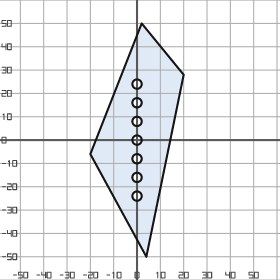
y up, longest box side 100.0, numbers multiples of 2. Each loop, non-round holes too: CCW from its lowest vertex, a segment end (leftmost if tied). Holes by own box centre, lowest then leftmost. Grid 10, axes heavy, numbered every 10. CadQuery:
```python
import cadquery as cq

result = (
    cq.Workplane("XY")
    .moveTo(4.0, -50.0)
    .lineTo(20.0, 28.0)
    .lineTo(2.0, 50.0)
    .lineTo(-20.0, -6.0)
    .close()
    .moveTo(0.0, -24.0)
    .circle(2.0)
    .moveTo(0.0, -16.0)
    .circle(2.0)
    .moveTo(0.0, -8.0)
    .circle(2.0)
    .moveTo(0.0, 0.0)
    .circle(2.0)
    .moveTo(0.0, 8.0)
    .circle(2.0)
    .moveTo(0.0, 16.0)
    .circle(2.0)
    .moveTo(0.0, 24.0)
    .circle(2.0)
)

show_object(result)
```